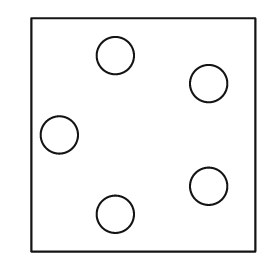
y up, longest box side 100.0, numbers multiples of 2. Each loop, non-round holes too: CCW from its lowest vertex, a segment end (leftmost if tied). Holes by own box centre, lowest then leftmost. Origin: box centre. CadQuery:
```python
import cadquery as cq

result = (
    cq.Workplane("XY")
    .moveTo(-48.0, -50.0)
    .lineTo(48.0, -50.0)
    .lineTo(48.0, 50.0)
    .lineTo(-48.0, 50.0)
    .close()
    .moveTo(-12.0, -34.0)
    .circle(8.0)
    .moveTo(28.0, -22.0)
    .circle(8.0)
    .moveTo(-36.0, 0.0)
    .circle(8.0)
    .moveTo(28.0, 22.0)
    .circle(8.0)
    .moveTo(-12.0, 34.0)
    .circle(8.0)
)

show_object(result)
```